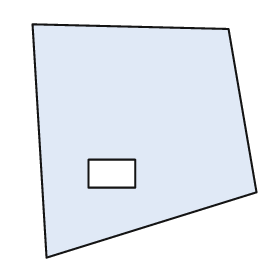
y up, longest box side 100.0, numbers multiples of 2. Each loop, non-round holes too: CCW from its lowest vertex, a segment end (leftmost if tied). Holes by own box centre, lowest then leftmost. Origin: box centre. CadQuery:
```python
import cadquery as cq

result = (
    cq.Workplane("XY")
    .moveTo(-42.0, -50.0)
    .lineTo(48.0, -22.0)
    .lineTo(36.0, 48.0)
    .lineTo(-48.0, 50.0)
    .close()
    .moveTo(-24.0, -20.0)
    .lineTo(-4.0, -20.0)
    .lineTo(-4.0, -8.0)
    .lineTo(-24.0, -8.0)
    .close()
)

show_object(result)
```